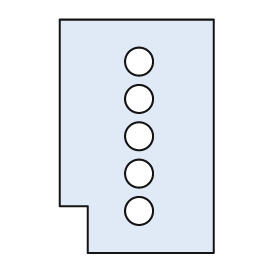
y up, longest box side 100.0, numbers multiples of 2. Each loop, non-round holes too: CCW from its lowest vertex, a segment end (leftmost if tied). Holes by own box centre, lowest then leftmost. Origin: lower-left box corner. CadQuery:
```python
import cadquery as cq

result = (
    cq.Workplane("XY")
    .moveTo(12.0, 0.0)
    .lineTo(66.0, 0.0)
    .lineTo(66.0, 100.0)
    .lineTo(0.0, 100.0)
    .lineTo(0.0, 20.0)
    .lineTo(12.0, 20.0)
    .close()
    .moveTo(34.0, 18.0)
    .circle(6.0)
    .moveTo(34.0, 34.0)
    .circle(6.0)
    .moveTo(34.0, 50.0)
    .circle(6.0)
    .moveTo(34.0, 66.0)
    .circle(6.0)
    .moveTo(34.0, 82.0)
    .circle(6.0)
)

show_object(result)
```